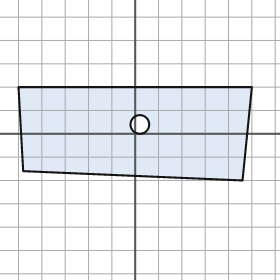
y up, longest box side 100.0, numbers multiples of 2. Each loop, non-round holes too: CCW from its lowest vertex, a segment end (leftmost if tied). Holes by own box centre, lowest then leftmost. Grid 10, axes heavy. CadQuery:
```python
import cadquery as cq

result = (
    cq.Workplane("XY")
    .moveTo(46.0, -20.0)
    .lineTo(50.0, 20.0)
    .lineTo(-50.0, 20.0)
    .lineTo(-48.0, -16.0)
    .close()
    .moveTo(2.0, 4.0)
    .circle(4.0)
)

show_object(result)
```